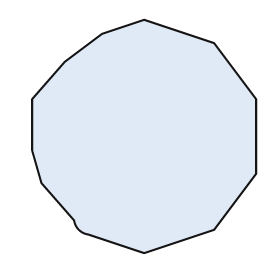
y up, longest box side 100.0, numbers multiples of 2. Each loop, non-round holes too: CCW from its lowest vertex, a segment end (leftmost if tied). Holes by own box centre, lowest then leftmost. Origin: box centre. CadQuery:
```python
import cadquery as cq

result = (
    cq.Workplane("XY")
    .moveTo(0.0, -50.0)
    .lineTo(30.0, -40.0)
    .lineTo(48.0, -16.0)
    .lineTo(48.0, 16.0)
    .lineTo(30.0, 40.0)
    .lineTo(0.0, 50.0)
    .lineTo(-18.0, 44.0)
    .lineTo(-34.0, 32.0)
    .lineTo(-48.0, 16.0)
    .lineTo(-48.0, -6.0)
    .lineTo(-44.0, -20.0)
    .lineTo(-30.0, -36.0)
    .threePointArc((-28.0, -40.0), (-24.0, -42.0))
    .close()
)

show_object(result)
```